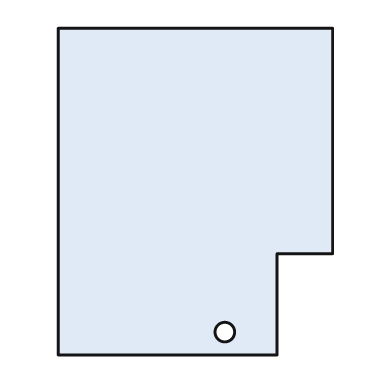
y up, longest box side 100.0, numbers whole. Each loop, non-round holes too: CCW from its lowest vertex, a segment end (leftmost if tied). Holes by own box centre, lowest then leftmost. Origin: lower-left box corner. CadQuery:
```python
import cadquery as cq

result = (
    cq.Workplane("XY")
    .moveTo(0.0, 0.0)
    .lineTo(67.0, 0.0)
    .lineTo(67.0, 31.0)
    .lineTo(84.0, 31.0)
    .lineTo(84.0, 100.0)
    .lineTo(0.0, 100.0)
    .close()
    .moveTo(51.0, 7.0)
    .circle(3.0)
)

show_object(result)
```